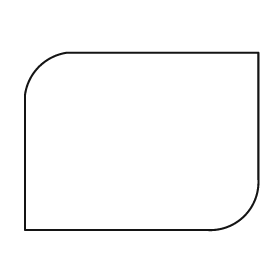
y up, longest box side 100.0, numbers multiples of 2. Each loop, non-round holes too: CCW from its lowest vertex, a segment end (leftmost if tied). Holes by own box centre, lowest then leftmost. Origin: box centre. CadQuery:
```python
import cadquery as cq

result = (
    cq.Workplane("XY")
    .moveTo(-50.0, -38.0)
    .lineTo(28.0, -38.0)
    .threePointArc((44.0, -32.0), (50.0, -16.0))
    .lineTo(50.0, 38.0)
    .lineTo(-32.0, 38.0)
    .threePointArc((-44.0, 32.0), (-50.0, 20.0))
    .close()
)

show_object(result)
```